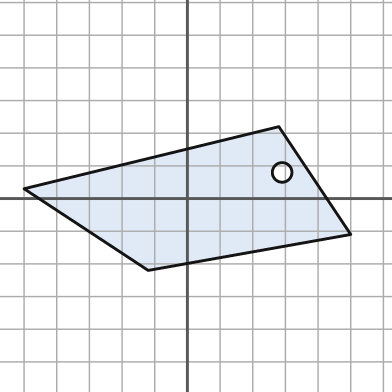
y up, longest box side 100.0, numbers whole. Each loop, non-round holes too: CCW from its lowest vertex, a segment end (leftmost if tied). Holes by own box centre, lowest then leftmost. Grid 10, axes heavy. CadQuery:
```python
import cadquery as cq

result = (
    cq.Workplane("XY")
    .moveTo(-12.0, -22.0)
    .lineTo(50.0, -11.0)
    .lineTo(28.0, 22.0)
    .lineTo(-50.0, 3.0)
    .close()
    .moveTo(29.0, 8.0)
    .circle(3.0)
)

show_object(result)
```